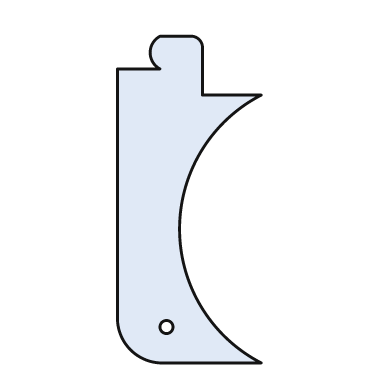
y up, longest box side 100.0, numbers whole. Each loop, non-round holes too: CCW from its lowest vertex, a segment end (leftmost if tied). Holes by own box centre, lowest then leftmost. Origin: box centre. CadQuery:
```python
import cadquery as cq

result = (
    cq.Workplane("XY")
    .moveTo(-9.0, -50.0)
    .lineTo(22.0, -50.0)
    .threePointArc((-3.0, -9.0), (22.0, 32.0))
    .lineTo(4.0, 32.0)
    .lineTo(4.0, 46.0)
    .threePointArc((3.0, 49.0), (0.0, 50.0))
    .lineTo(-9.0, 50.0)
    .threePointArc((-12.0, 45.0), (-9.0, 40.0))
    .lineTo(-22.0, 40.0)
    .lineTo(-22.0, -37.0)
    .threePointArc((-18.0, -46.0), (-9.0, -50.0))
    .close()
    .moveTo(-7.0, -39.0)
    .circle(2.0)
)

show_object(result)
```